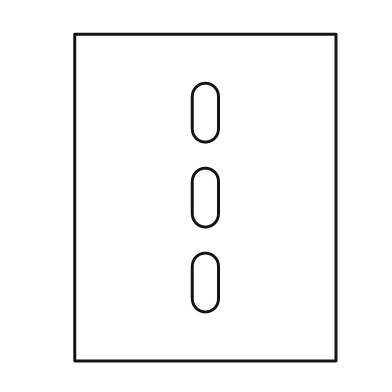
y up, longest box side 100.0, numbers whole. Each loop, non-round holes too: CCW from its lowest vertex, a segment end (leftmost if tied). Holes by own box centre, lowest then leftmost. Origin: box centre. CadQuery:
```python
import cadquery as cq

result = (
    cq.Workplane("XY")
    .moveTo(-40.0, -50.0)
    .lineTo(40.0, -50.0)
    .lineTo(40.0, 50.0)
    .lineTo(-40.0, 50.0)
    .close()
    .moveTo(-4.0, -31.0)
    .threePointArc((0.0, -35.0), (4.0, -31.0))
    .lineTo(4.0, -21.0)
    .threePointArc((0.0, -17.0), (-4.0, -21.0))
    .close()
    .moveTo(-4.0, -5.0)
    .threePointArc((0.0, -9.0), (4.0, -5.0))
    .lineTo(4.0, 5.0)
    .threePointArc((0.0, 9.0), (-4.0, 5.0))
    .close()
    .moveTo(-4.0, 21.0)
    .threePointArc((0.0, 17.0), (4.0, 21.0))
    .lineTo(4.0, 31.0)
    .threePointArc((0.0, 35.0), (-4.0, 31.0))
    .close()
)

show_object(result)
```